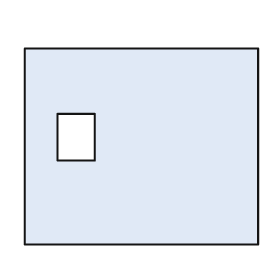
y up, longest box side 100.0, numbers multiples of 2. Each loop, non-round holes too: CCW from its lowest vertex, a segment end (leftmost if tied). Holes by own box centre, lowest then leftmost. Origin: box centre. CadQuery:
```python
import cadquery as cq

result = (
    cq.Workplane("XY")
    .moveTo(-50.0, -42.0)
    .lineTo(50.0, -42.0)
    .lineTo(50.0, 42.0)
    .lineTo(-50.0, 42.0)
    .close()
    .moveTo(-36.0, -6.0)
    .lineTo(-20.0, -6.0)
    .lineTo(-20.0, 14.0)
    .lineTo(-36.0, 14.0)
    .close()
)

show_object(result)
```